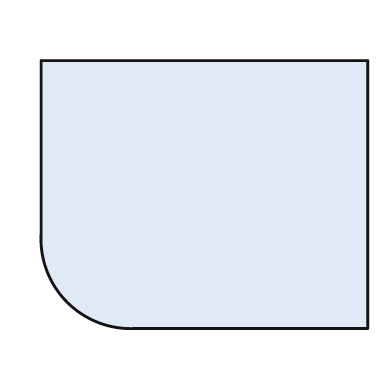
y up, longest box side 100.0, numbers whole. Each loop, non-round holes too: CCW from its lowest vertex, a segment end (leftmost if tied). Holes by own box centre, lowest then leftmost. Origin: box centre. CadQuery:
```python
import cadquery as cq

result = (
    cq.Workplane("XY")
    .moveTo(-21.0, -41.0)
    .lineTo(50.0, -41.0)
    .lineTo(50.0, 41.0)
    .lineTo(-50.0, 41.0)
    .lineTo(-50.0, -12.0)
    .threePointArc((-42.0, -33.0), (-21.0, -41.0))
    .close()
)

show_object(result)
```